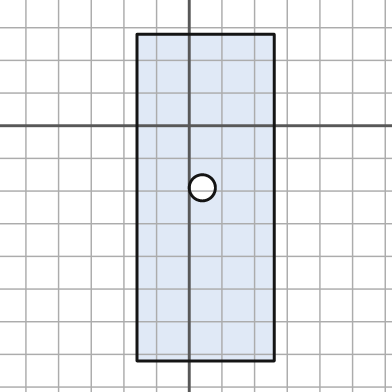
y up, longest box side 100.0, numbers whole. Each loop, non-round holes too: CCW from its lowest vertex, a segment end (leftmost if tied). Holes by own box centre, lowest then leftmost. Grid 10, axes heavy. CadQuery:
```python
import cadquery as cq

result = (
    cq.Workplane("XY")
    .moveTo(-16.0, -72.0)
    .lineTo(26.0, -72.0)
    .lineTo(26.0, 28.0)
    .lineTo(-16.0, 28.0)
    .close()
    .moveTo(4.0, -19.0)
    .circle(4.0)
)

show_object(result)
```